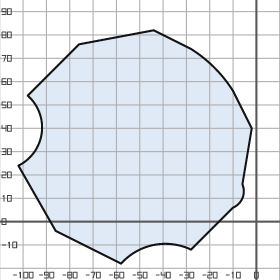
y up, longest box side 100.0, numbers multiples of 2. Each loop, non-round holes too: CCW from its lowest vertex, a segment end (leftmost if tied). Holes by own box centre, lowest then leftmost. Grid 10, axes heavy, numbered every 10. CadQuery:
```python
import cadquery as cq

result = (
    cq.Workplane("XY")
    .moveTo(-58.0, -18.0)
    .threePointArc((-44.0, -10.0), (-28.0, -12.0))
    .lineTo(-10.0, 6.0)
    .threePointArc((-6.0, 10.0), (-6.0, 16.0))
    .lineTo(-2.0, 40.0)
    .lineTo(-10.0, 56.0)
    .threePointArc((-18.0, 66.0), (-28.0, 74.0))
    .lineTo(-44.0, 82.0)
    .lineTo(-76.0, 76.0)
    .lineTo(-98.0, 54.0)
    .threePointArc((-92.0, 38.0), (-102.0, 24.0))
    .lineTo(-86.0, -4.0)
    .close()
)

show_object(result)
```